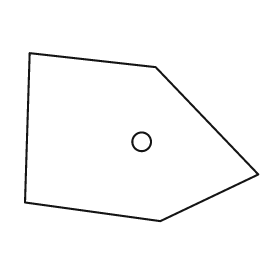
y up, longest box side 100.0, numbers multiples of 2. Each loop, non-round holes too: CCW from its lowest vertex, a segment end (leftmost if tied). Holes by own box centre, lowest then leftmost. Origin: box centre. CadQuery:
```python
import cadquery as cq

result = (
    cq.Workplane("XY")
    .moveTo(8.0, -36.0)
    .lineTo(50.0, -16.0)
    .lineTo(6.0, 30.0)
    .lineTo(-48.0, 36.0)
    .lineTo(-50.0, -28.0)
    .close()
    .moveTo(0.0, -2.0)
    .circle(4.0)
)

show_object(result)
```